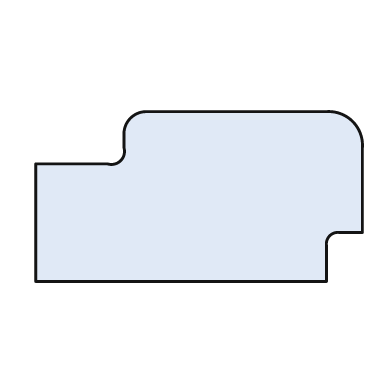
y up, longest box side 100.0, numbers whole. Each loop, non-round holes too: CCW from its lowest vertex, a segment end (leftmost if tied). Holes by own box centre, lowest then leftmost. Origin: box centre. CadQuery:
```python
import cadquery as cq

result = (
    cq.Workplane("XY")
    .moveTo(-50.0, -26.0)
    .lineTo(39.0, -26.0)
    .lineTo(39.0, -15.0)
    .threePointArc((40.0, -12.0), (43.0, -11.0))
    .lineTo(50.0, -11.0)
    .lineTo(50.0, 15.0)
    .threePointArc((47.0, 23.0), (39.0, 26.0))
    .lineTo(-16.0, 26.0)
    .threePointArc((-21.0, 24.0), (-23.0, 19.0))
    .lineTo(-23.0, 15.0)
    .threePointArc((-24.0, 11.0), (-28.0, 10.0))
    .lineTo(-50.0, 10.0)
    .close()
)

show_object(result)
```